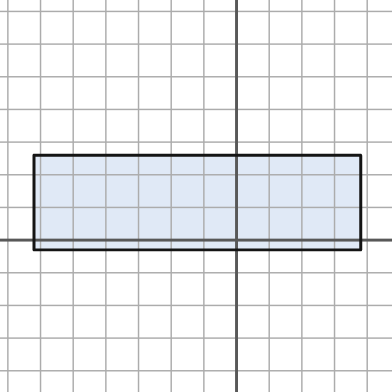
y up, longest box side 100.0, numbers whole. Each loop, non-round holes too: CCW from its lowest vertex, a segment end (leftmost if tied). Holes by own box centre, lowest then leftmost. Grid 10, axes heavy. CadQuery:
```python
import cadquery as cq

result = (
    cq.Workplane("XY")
    .moveTo(-62.0, -3.0)
    .lineTo(38.0, -3.0)
    .lineTo(38.0, 26.0)
    .lineTo(-62.0, 26.0)
    .close()
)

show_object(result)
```